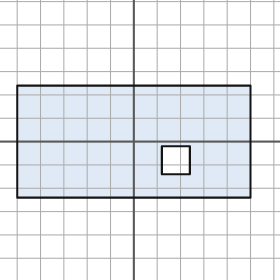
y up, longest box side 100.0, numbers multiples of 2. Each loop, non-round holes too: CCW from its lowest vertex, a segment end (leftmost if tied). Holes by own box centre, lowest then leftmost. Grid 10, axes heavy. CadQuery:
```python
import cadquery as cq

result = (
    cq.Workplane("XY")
    .moveTo(-50.0, -24.0)
    .lineTo(50.0, -24.0)
    .lineTo(50.0, 24.0)
    .lineTo(-50.0, 24.0)
    .close()
    .moveTo(12.0, -14.0)
    .lineTo(24.0, -14.0)
    .lineTo(24.0, -2.0)
    .lineTo(12.0, -2.0)
    .close()
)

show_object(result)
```